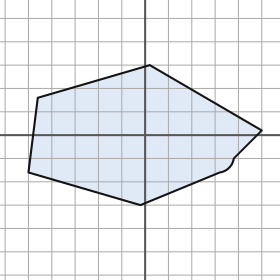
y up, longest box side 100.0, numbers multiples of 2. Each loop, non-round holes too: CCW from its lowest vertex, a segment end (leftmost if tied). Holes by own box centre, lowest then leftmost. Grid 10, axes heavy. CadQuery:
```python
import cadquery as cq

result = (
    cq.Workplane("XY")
    .moveTo(-2.0, -30.0)
    .lineTo(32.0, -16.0)
    .threePointArc((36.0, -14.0), (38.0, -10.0))
    .lineTo(50.0, 2.0)
    .lineTo(2.0, 30.0)
    .lineTo(-46.0, 16.0)
    .lineTo(-50.0, -16.0)
    .close()
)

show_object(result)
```